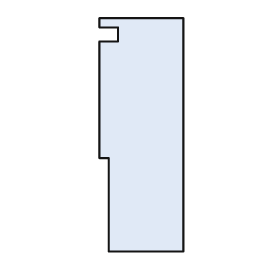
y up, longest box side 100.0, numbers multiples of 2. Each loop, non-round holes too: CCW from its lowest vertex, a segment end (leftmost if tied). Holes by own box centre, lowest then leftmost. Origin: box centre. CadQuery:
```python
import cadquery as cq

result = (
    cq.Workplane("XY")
    .moveTo(-14.0, -50.0)
    .lineTo(18.0, -50.0)
    .lineTo(18.0, 50.0)
    .lineTo(-18.0, 50.0)
    .lineTo(-18.0, 46.0)
    .lineTo(-10.0, 46.0)
    .lineTo(-10.0, 40.0)
    .lineTo(-18.0, 40.0)
    .lineTo(-18.0, -10.0)
    .lineTo(-14.0, -10.0)
    .close()
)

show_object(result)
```